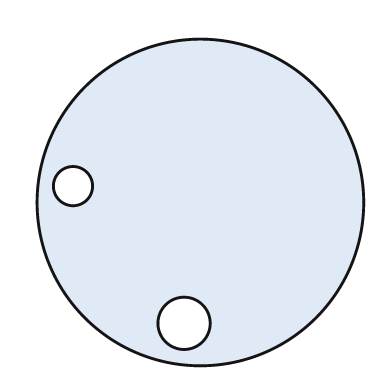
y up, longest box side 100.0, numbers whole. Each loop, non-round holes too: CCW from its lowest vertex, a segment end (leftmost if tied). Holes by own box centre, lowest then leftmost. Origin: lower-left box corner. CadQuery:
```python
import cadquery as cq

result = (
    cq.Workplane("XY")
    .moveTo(50.0, 50.0)
    .circle(50.0)
    .moveTo(45.0, 13.0)
    .circle(8.0)
    .moveTo(11.0, 55.0)
    .circle(6.0)
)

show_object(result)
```